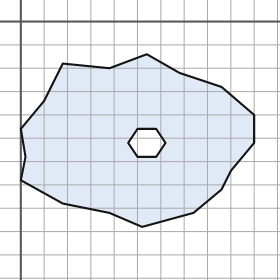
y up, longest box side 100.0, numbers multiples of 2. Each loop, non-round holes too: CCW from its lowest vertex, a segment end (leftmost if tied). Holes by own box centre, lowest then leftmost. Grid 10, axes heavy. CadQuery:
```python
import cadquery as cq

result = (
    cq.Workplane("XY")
    .moveTo(52.0, -88.0)
    .lineTo(74.0, -82.0)
    .lineTo(86.0, -72.0)
    .lineTo(90.0, -64.0)
    .lineTo(100.0, -52.0)
    .lineTo(100.0, -40.0)
    .lineTo(86.0, -28.0)
    .lineTo(68.0, -22.0)
    .lineTo(54.0, -14.0)
    .lineTo(38.0, -20.0)
    .lineTo(18.0, -18.0)
    .lineTo(10.0, -34.0)
    .lineTo(0.0, -46.0)
    .lineTo(2.0, -58.0)
    .lineTo(0.0, -68.0)
    .lineTo(18.0, -78.0)
    .lineTo(38.0, -82.0)
    .close()
    .moveTo(50.0, -58.0)
    .lineTo(58.0, -58.0)
    .lineTo(62.0, -52.0)
    .lineTo(58.0, -46.0)
    .lineTo(50.0, -46.0)
    .lineTo(46.0, -52.0)
    .close()
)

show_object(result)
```